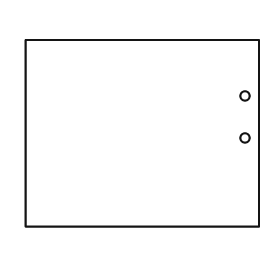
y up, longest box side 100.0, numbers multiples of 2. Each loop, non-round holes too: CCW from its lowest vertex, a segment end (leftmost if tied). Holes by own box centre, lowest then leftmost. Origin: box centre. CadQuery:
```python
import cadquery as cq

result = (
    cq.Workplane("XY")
    .moveTo(-50.0, -40.0)
    .lineTo(50.0, -40.0)
    .lineTo(50.0, 40.0)
    .lineTo(-50.0, 40.0)
    .close()
    .moveTo(44.0, -2.0)
    .circle(2.0)
    .moveTo(44.0, 16.0)
    .circle(2.0)
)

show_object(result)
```